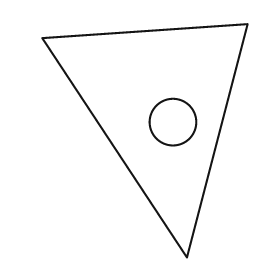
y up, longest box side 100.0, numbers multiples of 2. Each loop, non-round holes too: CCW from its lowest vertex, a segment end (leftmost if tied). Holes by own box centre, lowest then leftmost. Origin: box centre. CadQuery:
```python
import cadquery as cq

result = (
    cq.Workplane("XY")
    .moveTo(18.0, -50.0)
    .lineTo(44.0, 50.0)
    .lineTo(-44.0, 44.0)
    .close()
    .moveTo(12.0, 8.0)
    .circle(10.0)
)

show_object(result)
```